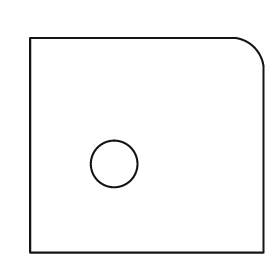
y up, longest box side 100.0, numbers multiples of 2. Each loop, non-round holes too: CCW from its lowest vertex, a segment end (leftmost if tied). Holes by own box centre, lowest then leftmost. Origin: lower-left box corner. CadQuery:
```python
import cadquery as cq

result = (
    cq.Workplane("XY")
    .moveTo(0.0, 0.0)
    .lineTo(100.0, 0.0)
    .lineTo(100.0, 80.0)
    .threePointArc((96.0, 88.0), (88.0, 92.0))
    .lineTo(0.0, 92.0)
    .close()
    .moveTo(36.0, 38.0)
    .circle(10.0)
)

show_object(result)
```